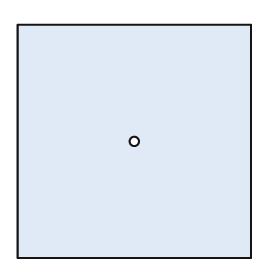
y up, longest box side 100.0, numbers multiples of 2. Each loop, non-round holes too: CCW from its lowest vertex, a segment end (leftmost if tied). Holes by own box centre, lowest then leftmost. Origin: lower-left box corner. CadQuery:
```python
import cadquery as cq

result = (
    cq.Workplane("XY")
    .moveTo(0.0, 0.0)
    .lineTo(100.0, 0.0)
    .lineTo(100.0, 100.0)
    .lineTo(0.0, 100.0)
    .close()
    .moveTo(50.0, 50.0)
    .circle(2.0)
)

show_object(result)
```